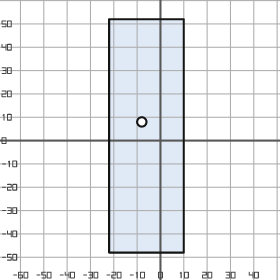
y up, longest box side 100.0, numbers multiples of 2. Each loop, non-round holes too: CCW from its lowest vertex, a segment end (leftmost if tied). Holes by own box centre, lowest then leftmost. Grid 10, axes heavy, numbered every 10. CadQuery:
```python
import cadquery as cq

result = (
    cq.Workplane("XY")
    .moveTo(-22.0, -48.0)
    .lineTo(10.0, -48.0)
    .lineTo(10.0, 52.0)
    .lineTo(-22.0, 52.0)
    .close()
    .moveTo(-8.0, 8.0)
    .circle(2.0)
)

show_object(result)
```